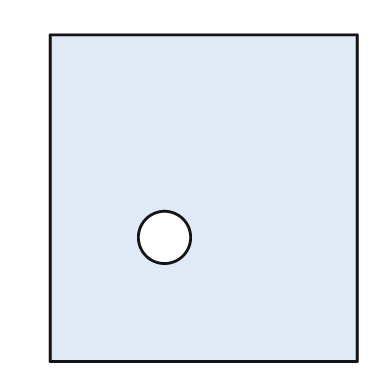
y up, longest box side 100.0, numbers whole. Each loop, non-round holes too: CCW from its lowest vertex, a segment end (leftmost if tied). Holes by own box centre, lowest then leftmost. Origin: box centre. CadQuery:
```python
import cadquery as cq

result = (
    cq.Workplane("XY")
    .moveTo(-47.0, -50.0)
    .lineTo(47.0, -50.0)
    .lineTo(47.0, 50.0)
    .lineTo(-47.0, 50.0)
    .close()
    .moveTo(-12.0, -12.0)
    .circle(8.0)
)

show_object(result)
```